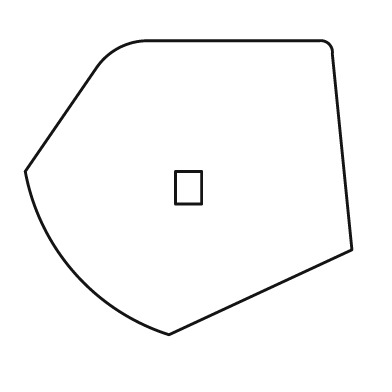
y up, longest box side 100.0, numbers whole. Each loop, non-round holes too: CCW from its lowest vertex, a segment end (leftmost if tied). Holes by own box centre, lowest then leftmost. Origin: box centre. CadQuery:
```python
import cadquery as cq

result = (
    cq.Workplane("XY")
    .moveTo(-6.0, -45.0)
    .lineTo(50.0, -19.0)
    .lineTo(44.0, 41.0)
    .threePointArc((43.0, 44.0), (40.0, 45.0))
    .lineTo(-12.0, 45.0)
    .threePointArc((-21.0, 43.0), (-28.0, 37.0))
    .lineTo(-50.0, 5.0)
    .threePointArc((-35.0, -26.0), (-6.0, -45.0))
    .close()
    .moveTo(-4.0, -5.0)
    .lineTo(4.0, -5.0)
    .lineTo(4.0, 5.0)
    .lineTo(-4.0, 5.0)
    .close()
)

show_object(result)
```